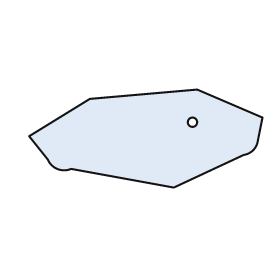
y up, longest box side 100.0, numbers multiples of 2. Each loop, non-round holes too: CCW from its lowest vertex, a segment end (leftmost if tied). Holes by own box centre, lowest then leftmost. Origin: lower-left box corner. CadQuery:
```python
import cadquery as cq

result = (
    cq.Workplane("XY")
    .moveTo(62.0, 0.0)
    .lineTo(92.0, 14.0)
    .threePointArc((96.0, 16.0), (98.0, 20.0))
    .lineTo(100.0, 30.0)
    .lineTo(72.0, 42.0)
    .lineTo(26.0, 38.0)
    .lineTo(0.0, 22.0)
    .lineTo(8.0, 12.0)
    .threePointArc((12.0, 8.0), (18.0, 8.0))
    .close()
    .moveTo(70.0, 28.0)
    .circle(2.0)
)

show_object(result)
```